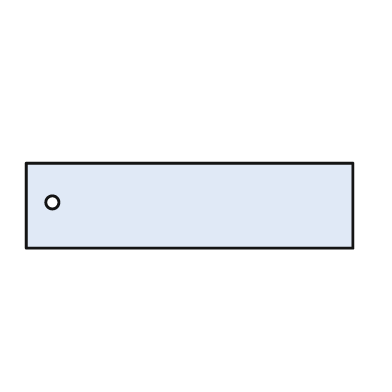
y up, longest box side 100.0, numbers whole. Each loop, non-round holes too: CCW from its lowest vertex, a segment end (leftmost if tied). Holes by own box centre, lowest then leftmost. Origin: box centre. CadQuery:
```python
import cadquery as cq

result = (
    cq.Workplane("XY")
    .moveTo(-50.0, -13.0)
    .lineTo(50.0, -13.0)
    .lineTo(50.0, 13.0)
    .lineTo(-50.0, 13.0)
    .close()
    .moveTo(-42.0, 1.0)
    .circle(2.0)
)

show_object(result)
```